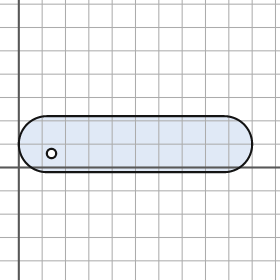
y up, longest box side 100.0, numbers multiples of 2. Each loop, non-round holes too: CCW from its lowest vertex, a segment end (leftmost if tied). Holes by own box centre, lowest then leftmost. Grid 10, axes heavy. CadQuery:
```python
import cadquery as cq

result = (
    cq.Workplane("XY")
    .moveTo(12.0, -2.0)
    .lineTo(88.0, -2.0)
    .threePointArc((100.0, 10.0), (88.0, 22.0))
    .lineTo(12.0, 22.0)
    .threePointArc((0.0, 10.0), (12.0, -2.0))
    .close()
    .moveTo(14.0, 6.0)
    .circle(2.0)
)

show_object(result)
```